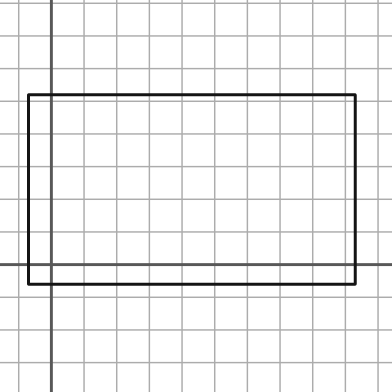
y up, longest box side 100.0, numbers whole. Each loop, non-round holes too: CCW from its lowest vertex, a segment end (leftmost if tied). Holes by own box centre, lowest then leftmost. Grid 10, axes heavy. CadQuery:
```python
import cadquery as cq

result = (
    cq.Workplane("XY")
    .moveTo(-7.0, -6.0)
    .lineTo(93.0, -6.0)
    .lineTo(93.0, 52.0)
    .lineTo(-7.0, 52.0)
    .close()
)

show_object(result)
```